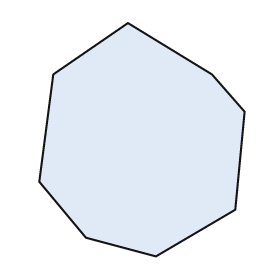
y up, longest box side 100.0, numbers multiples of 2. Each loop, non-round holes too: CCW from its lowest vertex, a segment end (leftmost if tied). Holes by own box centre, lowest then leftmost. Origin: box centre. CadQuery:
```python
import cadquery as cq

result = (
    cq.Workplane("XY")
    .moveTo(6.0, -50.0)
    .lineTo(40.0, -30.0)
    .lineTo(44.0, 12.0)
    .lineTo(30.0, 28.0)
    .lineTo(-6.0, 50.0)
    .lineTo(-38.0, 28.0)
    .lineTo(-44.0, -18.0)
    .lineTo(-24.0, -42.0)
    .close()
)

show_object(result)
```